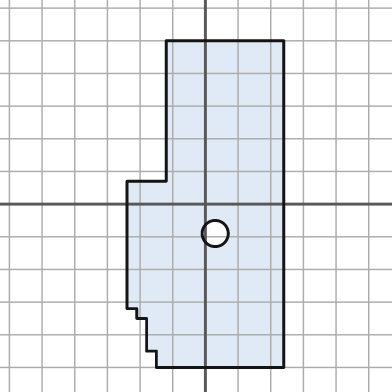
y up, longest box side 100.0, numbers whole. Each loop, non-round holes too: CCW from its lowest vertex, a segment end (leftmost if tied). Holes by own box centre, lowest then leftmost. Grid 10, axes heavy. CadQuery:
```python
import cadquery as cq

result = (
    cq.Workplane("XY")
    .moveTo(-15.0, -50.0)
    .lineTo(24.0, -50.0)
    .lineTo(24.0, 50.0)
    .lineTo(-12.0, 50.0)
    .lineTo(-12.0, 7.0)
    .lineTo(-24.0, 7.0)
    .lineTo(-24.0, -32.0)
    .lineTo(-21.0, -32.0)
    .lineTo(-21.0, -35.0)
    .lineTo(-18.0, -35.0)
    .lineTo(-18.0, -45.0)
    .lineTo(-15.0, -45.0)
    .close()
    .moveTo(3.0, -9.0)
    .circle(4.0)
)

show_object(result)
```